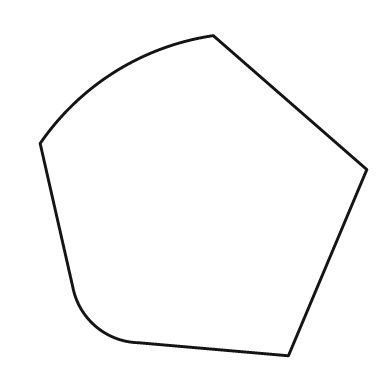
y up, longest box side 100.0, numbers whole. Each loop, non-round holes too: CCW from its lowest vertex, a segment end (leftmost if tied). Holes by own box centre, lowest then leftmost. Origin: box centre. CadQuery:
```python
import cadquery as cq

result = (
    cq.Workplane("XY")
    .moveTo(26.0, -49.0)
    .lineTo(50.0, 8.0)
    .lineTo(3.0, 49.0)
    .threePointArc((-27.0, 38.0), (-50.0, 16.0))
    .lineTo(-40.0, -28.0)
    .threePointArc((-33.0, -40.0), (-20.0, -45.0))
    .close()
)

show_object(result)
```